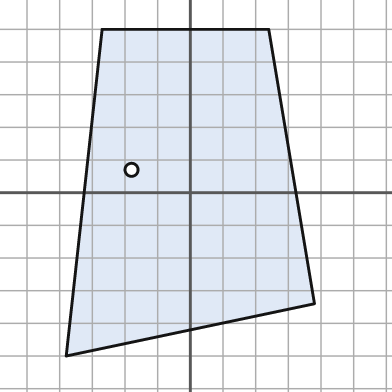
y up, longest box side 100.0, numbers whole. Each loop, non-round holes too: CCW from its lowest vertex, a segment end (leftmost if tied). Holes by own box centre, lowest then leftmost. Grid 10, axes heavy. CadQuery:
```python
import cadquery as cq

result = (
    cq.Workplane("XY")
    .moveTo(-38.0, -50.0)
    .lineTo(38.0, -34.0)
    .lineTo(24.0, 50.0)
    .lineTo(-27.0, 50.0)
    .close()
    .moveTo(-18.0, 7.0)
    .circle(2.0)
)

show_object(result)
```